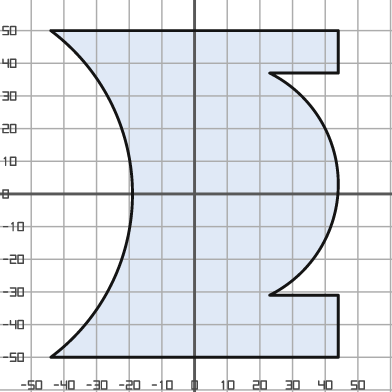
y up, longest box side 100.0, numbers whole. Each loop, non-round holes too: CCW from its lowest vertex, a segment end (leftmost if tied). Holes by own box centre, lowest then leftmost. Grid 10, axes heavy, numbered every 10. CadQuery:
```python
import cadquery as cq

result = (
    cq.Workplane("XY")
    .moveTo(-44.0, -50.0)
    .lineTo(44.0, -50.0)
    .lineTo(44.0, -31.0)
    .lineTo(23.0, -31.0)
    .threePointArc((44.0, 3.0), (23.0, 37.0))
    .lineTo(44.0, 37.0)
    .lineTo(44.0, 50.0)
    .lineTo(-44.0, 50.0)
    .threePointArc((-19.0, 0.0), (-44.0, -50.0))
    .close()
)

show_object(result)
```